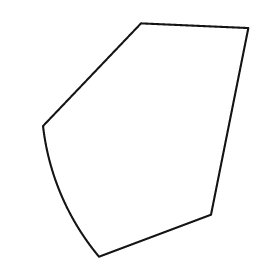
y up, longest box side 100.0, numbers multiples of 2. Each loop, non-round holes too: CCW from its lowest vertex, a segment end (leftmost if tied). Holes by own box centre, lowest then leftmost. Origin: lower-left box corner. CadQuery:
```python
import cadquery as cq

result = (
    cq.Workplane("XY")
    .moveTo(24.0, 0.0)
    .lineTo(72.0, 18.0)
    .lineTo(88.0, 98.0)
    .lineTo(42.0, 100.0)
    .lineTo(0.0, 56.0)
    .threePointArc((8.0, 26.0), (24.0, 0.0))
    .close()
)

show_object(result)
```